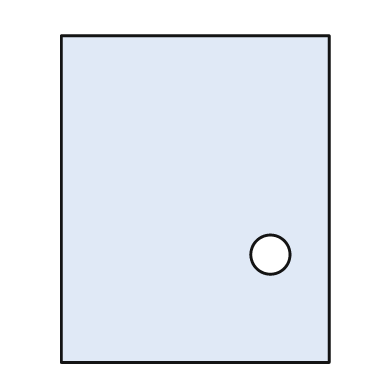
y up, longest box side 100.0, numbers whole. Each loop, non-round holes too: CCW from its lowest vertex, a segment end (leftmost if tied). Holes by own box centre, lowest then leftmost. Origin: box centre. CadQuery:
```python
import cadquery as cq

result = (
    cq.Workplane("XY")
    .moveTo(-41.0, -50.0)
    .lineTo(41.0, -50.0)
    .lineTo(41.0, 50.0)
    .lineTo(-41.0, 50.0)
    .close()
    .moveTo(23.0, -17.0)
    .circle(6.0)
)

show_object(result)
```